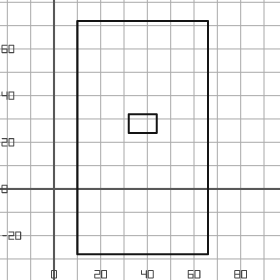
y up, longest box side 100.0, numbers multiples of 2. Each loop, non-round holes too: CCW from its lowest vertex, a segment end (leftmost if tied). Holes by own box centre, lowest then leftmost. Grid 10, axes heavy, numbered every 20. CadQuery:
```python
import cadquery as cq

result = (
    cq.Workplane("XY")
    .moveTo(10.0, -28.0)
    .lineTo(66.0, -28.0)
    .lineTo(66.0, 72.0)
    .lineTo(10.0, 72.0)
    .close()
    .moveTo(32.0, 24.0)
    .lineTo(44.0, 24.0)
    .lineTo(44.0, 32.0)
    .lineTo(32.0, 32.0)
    .close()
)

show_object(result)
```